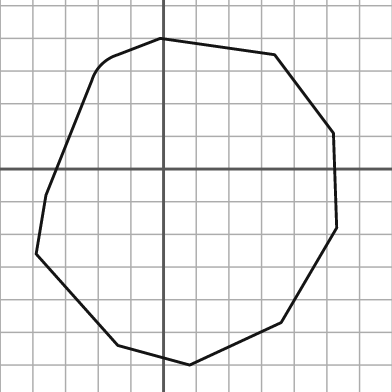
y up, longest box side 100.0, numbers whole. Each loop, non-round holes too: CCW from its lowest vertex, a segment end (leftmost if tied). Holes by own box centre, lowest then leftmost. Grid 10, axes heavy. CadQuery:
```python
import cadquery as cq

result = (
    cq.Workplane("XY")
    .moveTo(8.0, -60.0)
    .lineTo(36.0, -47.0)
    .lineTo(53.0, -18.0)
    .lineTo(52.0, 11.0)
    .lineTo(34.0, 35.0)
    .lineTo(-1.0, 40.0)
    .lineTo(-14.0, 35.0)
    .threePointArc((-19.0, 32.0), (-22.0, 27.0))
    .lineTo(-36.0, -8.0)
    .lineTo(-39.0, -26.0)
    .lineTo(-14.0, -54.0)
    .close()
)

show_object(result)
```